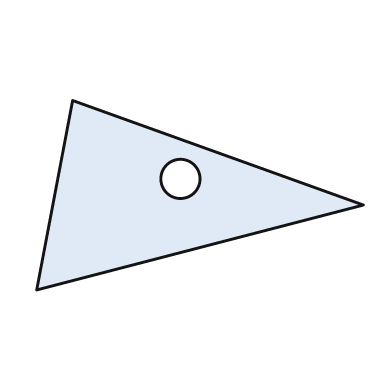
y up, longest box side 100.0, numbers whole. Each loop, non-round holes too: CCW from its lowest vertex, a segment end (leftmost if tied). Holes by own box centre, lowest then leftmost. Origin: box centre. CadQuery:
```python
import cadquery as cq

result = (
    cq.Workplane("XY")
    .moveTo(-50.0, -29.0)
    .lineTo(50.0, -3.0)
    .lineTo(-39.0, 29.0)
    .close()
    .moveTo(-6.0, 5.0)
    .circle(6.0)
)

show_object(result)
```